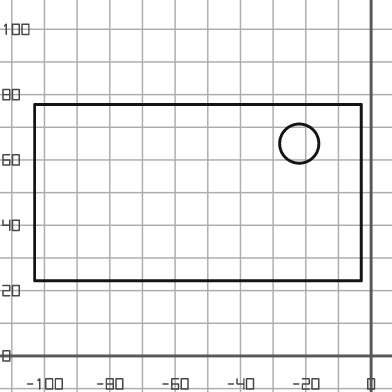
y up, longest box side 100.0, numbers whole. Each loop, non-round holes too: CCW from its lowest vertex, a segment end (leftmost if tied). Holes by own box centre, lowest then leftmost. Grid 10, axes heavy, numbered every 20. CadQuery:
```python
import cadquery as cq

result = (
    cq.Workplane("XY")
    .moveTo(-103.0, 23.0)
    .lineTo(-3.0, 23.0)
    .lineTo(-3.0, 77.0)
    .lineTo(-103.0, 77.0)
    .close()
    .moveTo(-22.0, 65.0)
    .circle(6.0)
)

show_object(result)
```